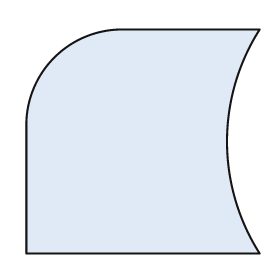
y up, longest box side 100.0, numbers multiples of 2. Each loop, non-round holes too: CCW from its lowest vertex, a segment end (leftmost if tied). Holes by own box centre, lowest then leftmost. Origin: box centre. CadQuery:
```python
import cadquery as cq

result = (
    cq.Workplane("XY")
    .moveTo(-50.0, -48.0)
    .lineTo(50.0, -48.0)
    .threePointArc((36.0, 0.0), (50.0, 48.0))
    .lineTo(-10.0, 48.0)
    .threePointArc((-38.0, 36.0), (-50.0, 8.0))
    .close()
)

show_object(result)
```